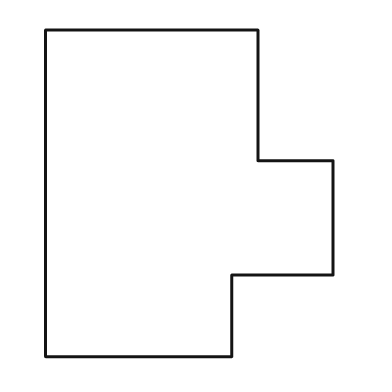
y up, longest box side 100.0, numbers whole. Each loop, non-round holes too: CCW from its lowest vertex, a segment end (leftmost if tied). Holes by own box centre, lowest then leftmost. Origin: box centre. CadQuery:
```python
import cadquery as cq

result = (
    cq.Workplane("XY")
    .moveTo(-44.0, -50.0)
    .lineTo(13.0, -50.0)
    .lineTo(13.0, -25.0)
    .lineTo(44.0, -25.0)
    .lineTo(44.0, 10.0)
    .lineTo(21.0, 10.0)
    .lineTo(21.0, 50.0)
    .lineTo(-44.0, 50.0)
    .close()
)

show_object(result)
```